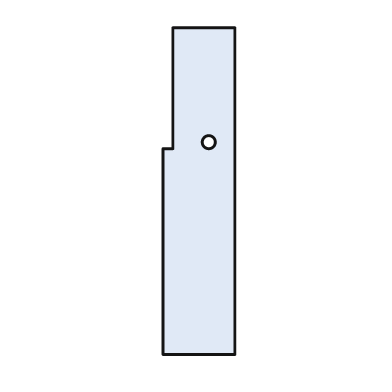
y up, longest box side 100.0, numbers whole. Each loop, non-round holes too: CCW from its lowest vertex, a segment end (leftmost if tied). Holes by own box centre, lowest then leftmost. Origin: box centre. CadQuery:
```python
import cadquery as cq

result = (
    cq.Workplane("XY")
    .moveTo(-11.0, -50.0)
    .lineTo(11.0, -50.0)
    .lineTo(11.0, 50.0)
    .lineTo(-8.0, 50.0)
    .lineTo(-8.0, 13.0)
    .lineTo(-11.0, 13.0)
    .close()
    .moveTo(3.0, 15.0)
    .circle(2.0)
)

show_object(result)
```